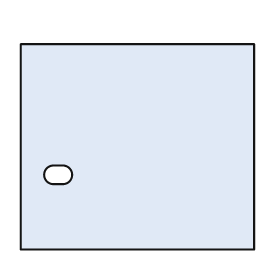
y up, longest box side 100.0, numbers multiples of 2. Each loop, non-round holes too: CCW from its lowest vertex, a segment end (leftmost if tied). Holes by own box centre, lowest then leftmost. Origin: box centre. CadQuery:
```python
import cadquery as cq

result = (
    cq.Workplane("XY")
    .moveTo(-50.0, -44.0)
    .lineTo(50.0, -44.0)
    .lineTo(50.0, 44.0)
    .lineTo(-50.0, 44.0)
    .close()
    .moveTo(-36.0, -16.0)
    .lineTo(-32.0, -16.0)
    .threePointArc((-28.0, -12.0), (-32.0, -8.0))
    .lineTo(-36.0, -8.0)
    .threePointArc((-40.0, -12.0), (-36.0, -16.0))
    .close()
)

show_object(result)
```